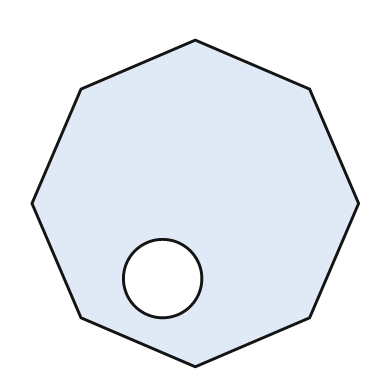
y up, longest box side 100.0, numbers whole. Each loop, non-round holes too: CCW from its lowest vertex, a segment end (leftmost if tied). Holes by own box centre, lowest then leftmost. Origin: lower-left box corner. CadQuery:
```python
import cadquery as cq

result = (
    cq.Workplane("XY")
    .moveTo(50.0, 0.0)
    .lineTo(85.0, 15.0)
    .lineTo(100.0, 50.0)
    .lineTo(85.0, 85.0)
    .lineTo(50.0, 100.0)
    .lineTo(15.0, 85.0)
    .lineTo(0.0, 50.0)
    .lineTo(15.0, 15.0)
    .close()
    .moveTo(40.0, 27.0)
    .circle(12.0)
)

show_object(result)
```